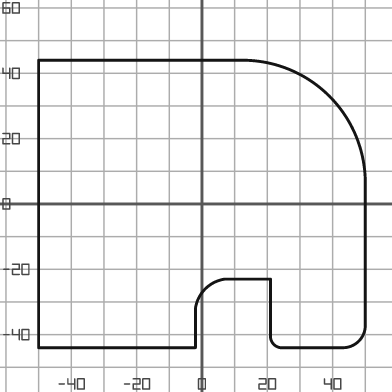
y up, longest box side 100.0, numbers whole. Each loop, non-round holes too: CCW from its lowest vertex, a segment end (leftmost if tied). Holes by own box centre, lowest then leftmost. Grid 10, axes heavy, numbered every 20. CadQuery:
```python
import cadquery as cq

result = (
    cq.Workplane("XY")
    .moveTo(-50.0, -44.0)
    .lineTo(-2.0, -44.0)
    .lineTo(-2.0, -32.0)
    .threePointArc((1.0, -26.0), (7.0, -23.0))
    .lineTo(21.0, -23.0)
    .lineTo(21.0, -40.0)
    .threePointArc((22.0, -43.0), (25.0, -44.0))
    .lineTo(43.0, -44.0)
    .threePointArc((48.0, -42.0), (50.0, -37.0))
    .lineTo(50.0, 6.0)
    .threePointArc((39.0, 33.0), (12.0, 44.0))
    .lineTo(-50.0, 44.0)
    .close()
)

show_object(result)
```